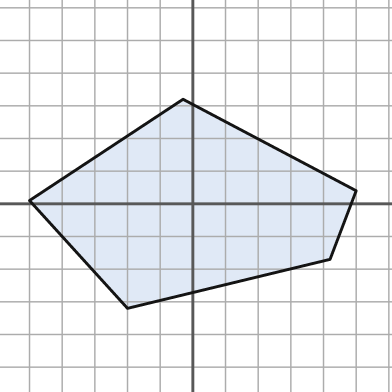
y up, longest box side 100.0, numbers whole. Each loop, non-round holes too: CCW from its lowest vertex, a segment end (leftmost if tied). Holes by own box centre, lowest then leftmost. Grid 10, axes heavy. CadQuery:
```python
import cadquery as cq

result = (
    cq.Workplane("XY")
    .moveTo(-20.0, -32.0)
    .lineTo(42.0, -17.0)
    .lineTo(50.0, 4.0)
    .lineTo(-3.0, 32.0)
    .lineTo(-50.0, 1.0)
    .close()
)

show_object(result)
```